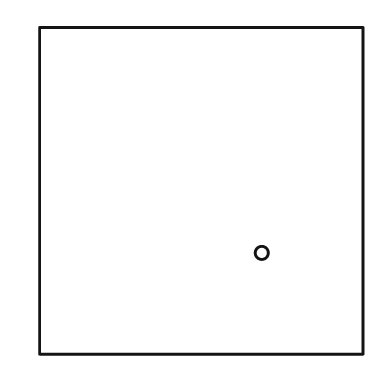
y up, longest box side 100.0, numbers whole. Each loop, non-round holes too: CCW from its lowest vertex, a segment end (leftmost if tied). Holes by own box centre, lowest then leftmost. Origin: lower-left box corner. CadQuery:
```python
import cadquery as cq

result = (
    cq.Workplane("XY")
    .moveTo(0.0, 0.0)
    .lineTo(99.0, 0.0)
    .lineTo(99.0, 100.0)
    .lineTo(0.0, 100.0)
    .close()
    .moveTo(68.0, 31.0)
    .circle(2.0)
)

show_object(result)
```